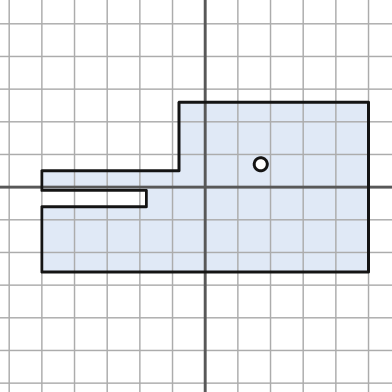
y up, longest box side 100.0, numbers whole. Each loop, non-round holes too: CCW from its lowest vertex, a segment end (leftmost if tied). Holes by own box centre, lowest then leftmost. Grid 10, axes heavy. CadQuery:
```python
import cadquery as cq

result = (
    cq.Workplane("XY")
    .moveTo(-50.0, -26.0)
    .lineTo(50.0, -26.0)
    .lineTo(50.0, 26.0)
    .lineTo(-8.0, 26.0)
    .lineTo(-8.0, 5.0)
    .lineTo(-50.0, 5.0)
    .lineTo(-50.0, -1.0)
    .lineTo(-18.0, -1.0)
    .lineTo(-18.0, -6.0)
    .lineTo(-50.0, -6.0)
    .close()
    .moveTo(17.0, 7.0)
    .circle(2.0)
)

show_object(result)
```